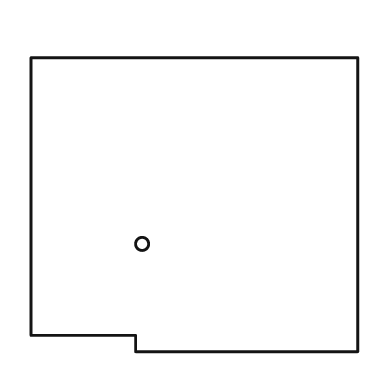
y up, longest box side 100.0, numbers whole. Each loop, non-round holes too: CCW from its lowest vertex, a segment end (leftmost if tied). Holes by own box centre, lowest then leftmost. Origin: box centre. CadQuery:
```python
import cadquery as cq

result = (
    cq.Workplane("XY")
    .moveTo(-18.0, -45.0)
    .lineTo(50.0, -45.0)
    .lineTo(50.0, 45.0)
    .lineTo(-50.0, 45.0)
    .lineTo(-50.0, -40.0)
    .lineTo(-18.0, -40.0)
    .close()
    .moveTo(-16.0, -12.0)
    .circle(2.0)
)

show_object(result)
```